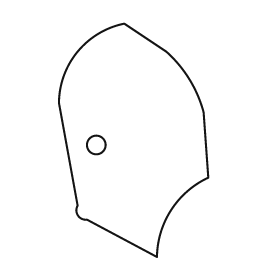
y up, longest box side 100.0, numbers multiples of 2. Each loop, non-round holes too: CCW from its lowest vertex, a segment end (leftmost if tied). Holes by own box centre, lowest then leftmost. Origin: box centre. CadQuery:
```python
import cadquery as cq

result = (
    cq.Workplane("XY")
    .moveTo(10.0, -50.0)
    .threePointArc((16.0, -30.0), (32.0, -16.0))
    .lineTo(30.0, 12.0)
    .threePointArc((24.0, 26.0), (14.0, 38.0))
    .lineTo(-4.0, 50.0)
    .threePointArc((-24.0, 38.0), (-32.0, 16.0))
    .lineTo(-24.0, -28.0)
    .threePointArc((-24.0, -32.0), (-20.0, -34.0))
    .close()
    .moveTo(-16.0, -2.0)
    .circle(4.0)
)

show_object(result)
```